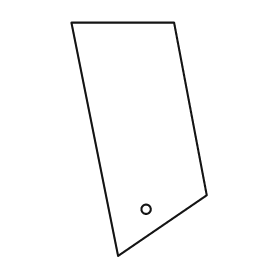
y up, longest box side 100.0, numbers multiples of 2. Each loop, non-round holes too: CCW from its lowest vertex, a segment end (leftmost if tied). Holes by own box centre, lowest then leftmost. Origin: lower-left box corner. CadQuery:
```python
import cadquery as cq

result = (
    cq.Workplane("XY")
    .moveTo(20.0, 0.0)
    .lineTo(58.0, 26.0)
    .lineTo(44.0, 100.0)
    .lineTo(0.0, 100.0)
    .close()
    .moveTo(32.0, 20.0)
    .circle(2.0)
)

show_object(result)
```